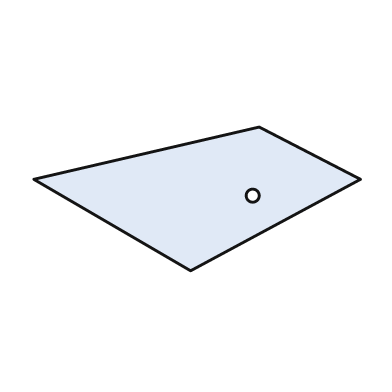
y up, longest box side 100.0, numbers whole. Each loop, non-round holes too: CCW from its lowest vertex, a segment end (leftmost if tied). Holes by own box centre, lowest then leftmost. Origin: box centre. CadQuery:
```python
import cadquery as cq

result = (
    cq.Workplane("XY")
    .moveTo(-2.0, -22.0)
    .lineTo(50.0, 6.0)
    .lineTo(19.0, 22.0)
    .lineTo(-50.0, 6.0)
    .close()
    .moveTo(17.0, 1.0)
    .circle(2.0)
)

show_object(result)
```